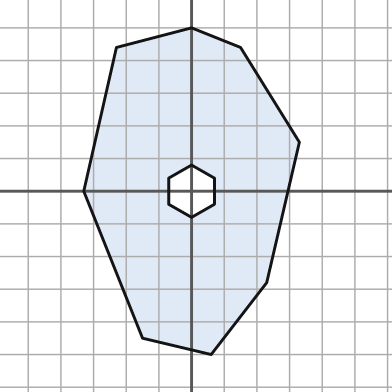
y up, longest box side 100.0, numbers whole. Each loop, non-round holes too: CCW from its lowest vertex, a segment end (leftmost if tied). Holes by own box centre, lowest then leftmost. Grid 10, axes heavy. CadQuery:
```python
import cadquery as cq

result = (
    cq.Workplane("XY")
    .moveTo(6.0, -50.0)
    .lineTo(23.0, -28.0)
    .lineTo(33.0, 15.0)
    .lineTo(15.0, 44.0)
    .lineTo(0.0, 50.0)
    .lineTo(-23.0, 44.0)
    .lineTo(-33.0, 0.0)
    .lineTo(-15.0, -45.0)
    .close()
    .moveTo(0.0, -8.0)
    .lineTo(7.0, -4.0)
    .lineTo(7.0, 4.0)
    .lineTo(0.0, 8.0)
    .lineTo(-7.0, 4.0)
    .lineTo(-7.0, -4.0)
    .close()
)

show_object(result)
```